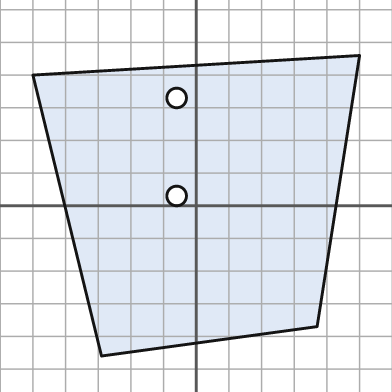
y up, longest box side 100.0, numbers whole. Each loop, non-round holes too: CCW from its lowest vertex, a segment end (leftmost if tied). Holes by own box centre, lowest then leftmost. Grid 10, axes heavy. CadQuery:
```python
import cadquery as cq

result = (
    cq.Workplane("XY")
    .moveTo(-29.0, -46.0)
    .lineTo(37.0, -37.0)
    .lineTo(50.0, 46.0)
    .lineTo(-50.0, 40.0)
    .close()
    .moveTo(-6.0, 3.0)
    .circle(3.0)
    .moveTo(-6.0, 33.0)
    .circle(3.0)
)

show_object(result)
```